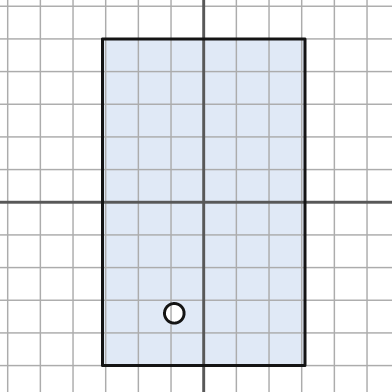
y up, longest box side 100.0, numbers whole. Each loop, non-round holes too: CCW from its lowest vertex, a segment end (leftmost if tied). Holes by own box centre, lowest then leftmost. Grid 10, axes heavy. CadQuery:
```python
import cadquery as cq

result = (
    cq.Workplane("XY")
    .moveTo(-31.0, -50.0)
    .lineTo(31.0, -50.0)
    .lineTo(31.0, 50.0)
    .lineTo(-31.0, 50.0)
    .close()
    .moveTo(-9.0, -34.0)
    .circle(3.0)
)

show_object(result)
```